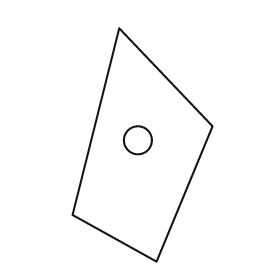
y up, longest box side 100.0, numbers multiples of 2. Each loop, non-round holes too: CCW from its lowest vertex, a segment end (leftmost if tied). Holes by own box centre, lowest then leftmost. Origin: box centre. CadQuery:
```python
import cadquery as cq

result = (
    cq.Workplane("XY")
    .moveTo(6.0, -50.0)
    .lineTo(30.0, 8.0)
    .lineTo(-10.0, 50.0)
    .lineTo(-30.0, -30.0)
    .close()
    .moveTo(-2.0, 2.0)
    .circle(6.0)
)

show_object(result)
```